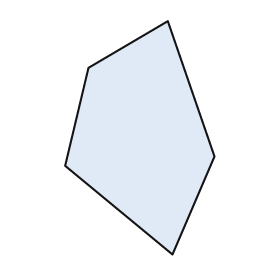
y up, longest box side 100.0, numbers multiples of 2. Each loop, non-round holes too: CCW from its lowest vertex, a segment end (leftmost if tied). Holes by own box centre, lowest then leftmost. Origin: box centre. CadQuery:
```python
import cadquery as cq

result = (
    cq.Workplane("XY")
    .moveTo(14.0, -50.0)
    .lineTo(32.0, -8.0)
    .lineTo(12.0, 50.0)
    .lineTo(-22.0, 30.0)
    .lineTo(-32.0, -12.0)
    .close()
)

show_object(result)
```